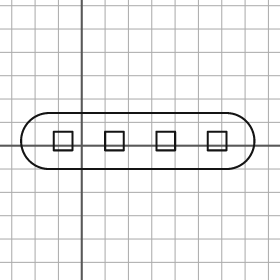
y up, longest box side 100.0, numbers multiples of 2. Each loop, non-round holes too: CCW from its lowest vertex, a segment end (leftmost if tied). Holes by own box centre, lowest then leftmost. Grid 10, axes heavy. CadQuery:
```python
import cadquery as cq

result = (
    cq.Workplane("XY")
    .moveTo(-14.0, -10.0)
    .lineTo(62.0, -10.0)
    .threePointArc((74.0, 2.0), (62.0, 14.0))
    .lineTo(-14.0, 14.0)
    .threePointArc((-26.0, 2.0), (-14.0, -10.0))
    .close()
    .moveTo(-12.0, -2.0)
    .lineTo(-4.0, -2.0)
    .lineTo(-4.0, 6.0)
    .lineTo(-12.0, 6.0)
    .close()
    .moveTo(10.0, -2.0)
    .lineTo(18.0, -2.0)
    .lineTo(18.0, 6.0)
    .lineTo(10.0, 6.0)
    .close()
    .moveTo(32.0, -2.0)
    .lineTo(40.0, -2.0)
    .lineTo(40.0, 6.0)
    .lineTo(32.0, 6.0)
    .close()
    .moveTo(54.0, -2.0)
    .lineTo(62.0, -2.0)
    .lineTo(62.0, 6.0)
    .lineTo(54.0, 6.0)
    .close()
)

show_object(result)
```